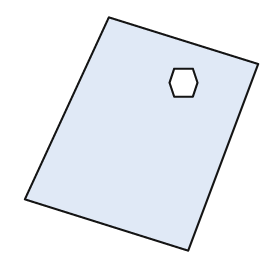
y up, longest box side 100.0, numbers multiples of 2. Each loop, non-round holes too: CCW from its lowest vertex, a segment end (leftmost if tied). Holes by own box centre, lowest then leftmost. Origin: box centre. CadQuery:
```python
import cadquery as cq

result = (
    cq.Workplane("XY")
    .moveTo(20.0, -50.0)
    .lineTo(50.0, 30.0)
    .lineTo(-14.0, 50.0)
    .lineTo(-50.0, -28.0)
    .close()
    .moveTo(14.0, 16.0)
    .lineTo(22.0, 16.0)
    .lineTo(24.0, 22.0)
    .lineTo(22.0, 28.0)
    .lineTo(14.0, 28.0)
    .lineTo(12.0, 22.0)
    .close()
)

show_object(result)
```